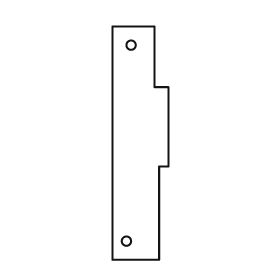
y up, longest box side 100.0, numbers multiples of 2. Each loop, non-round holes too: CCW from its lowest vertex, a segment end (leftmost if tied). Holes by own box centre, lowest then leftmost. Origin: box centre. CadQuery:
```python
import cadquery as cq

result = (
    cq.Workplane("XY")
    .moveTo(-12.0, -50.0)
    .lineTo(8.0, -50.0)
    .lineTo(8.0, -10.0)
    .lineTo(12.0, -10.0)
    .lineTo(12.0, 24.0)
    .lineTo(6.0, 24.0)
    .lineTo(6.0, 50.0)
    .lineTo(-12.0, 50.0)
    .close()
    .moveTo(-6.0, -42.0)
    .circle(2.0)
    .moveTo(-4.0, 42.0)
    .circle(2.0)
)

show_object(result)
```